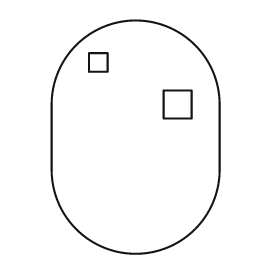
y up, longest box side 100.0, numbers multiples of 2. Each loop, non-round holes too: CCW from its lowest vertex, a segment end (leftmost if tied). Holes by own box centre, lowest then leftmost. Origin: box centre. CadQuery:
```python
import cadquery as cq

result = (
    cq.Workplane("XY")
    .moveTo(-36.0, -14.0)
    .threePointArc((0.0, -50.0), (36.0, -14.0))
    .lineTo(36.0, 14.0)
    .threePointArc((0.0, 50.0), (-36.0, 14.0))
    .close()
    .moveTo(12.0, 8.0)
    .lineTo(24.0, 8.0)
    .lineTo(24.0, 20.0)
    .lineTo(12.0, 20.0)
    .close()
    .moveTo(-20.0, 28.0)
    .lineTo(-12.0, 28.0)
    .lineTo(-12.0, 36.0)
    .lineTo(-20.0, 36.0)
    .close()
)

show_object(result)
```